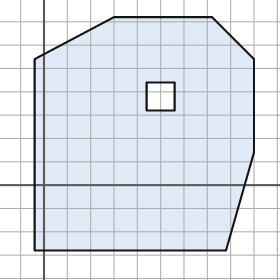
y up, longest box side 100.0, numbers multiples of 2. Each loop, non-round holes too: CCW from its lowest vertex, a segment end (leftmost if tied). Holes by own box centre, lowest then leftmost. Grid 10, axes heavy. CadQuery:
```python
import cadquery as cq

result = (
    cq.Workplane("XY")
    .moveTo(-4.0, -28.0)
    .lineTo(78.0, -28.0)
    .lineTo(90.0, 14.0)
    .lineTo(90.0, 54.0)
    .lineTo(72.0, 72.0)
    .lineTo(30.0, 72.0)
    .lineTo(-4.0, 54.0)
    .close()
    .moveTo(44.0, 32.0)
    .lineTo(56.0, 32.0)
    .lineTo(56.0, 44.0)
    .lineTo(44.0, 44.0)
    .close()
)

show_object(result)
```